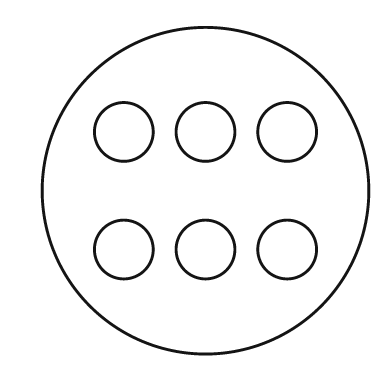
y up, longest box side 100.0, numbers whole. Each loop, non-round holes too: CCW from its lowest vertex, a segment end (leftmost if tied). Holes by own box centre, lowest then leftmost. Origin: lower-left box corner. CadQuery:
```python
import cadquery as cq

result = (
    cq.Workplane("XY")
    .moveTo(50.0, 50.0)
    .circle(50.0)
    .moveTo(25.0, 32.0)
    .circle(9.0)
    .moveTo(50.0, 32.0)
    .circle(9.0)
    .moveTo(75.0, 32.0)
    .circle(9.0)
    .moveTo(25.0, 68.0)
    .circle(9.0)
    .moveTo(50.0, 68.0)
    .circle(9.0)
    .moveTo(75.0, 68.0)
    .circle(9.0)
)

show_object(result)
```